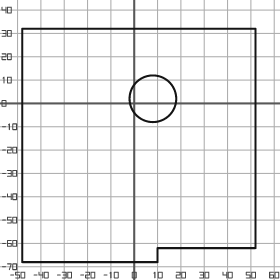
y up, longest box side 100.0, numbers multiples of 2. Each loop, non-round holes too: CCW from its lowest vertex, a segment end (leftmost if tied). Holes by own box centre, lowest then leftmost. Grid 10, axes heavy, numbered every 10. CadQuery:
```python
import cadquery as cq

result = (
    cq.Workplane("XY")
    .moveTo(-48.0, -68.0)
    .lineTo(10.0, -68.0)
    .lineTo(10.0, -62.0)
    .lineTo(52.0, -62.0)
    .lineTo(52.0, 32.0)
    .lineTo(-48.0, 32.0)
    .close()
    .moveTo(8.0, 2.0)
    .circle(10.0)
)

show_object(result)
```